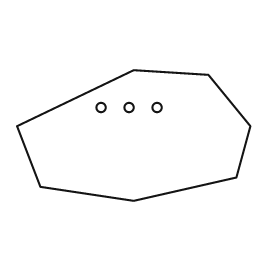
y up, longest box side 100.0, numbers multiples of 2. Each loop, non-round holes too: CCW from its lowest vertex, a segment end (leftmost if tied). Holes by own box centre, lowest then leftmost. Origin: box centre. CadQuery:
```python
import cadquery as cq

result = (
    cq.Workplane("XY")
    .moveTo(0.0, -28.0)
    .lineTo(44.0, -18.0)
    .lineTo(50.0, 4.0)
    .lineTo(32.0, 26.0)
    .lineTo(0.0, 28.0)
    .lineTo(-50.0, 4.0)
    .lineTo(-40.0, -22.0)
    .close()
    .moveTo(-14.0, 12.0)
    .circle(2.0)
    .moveTo(-2.0, 12.0)
    .circle(2.0)
    .moveTo(10.0, 12.0)
    .circle(2.0)
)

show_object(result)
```